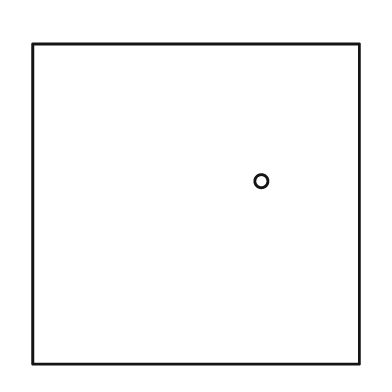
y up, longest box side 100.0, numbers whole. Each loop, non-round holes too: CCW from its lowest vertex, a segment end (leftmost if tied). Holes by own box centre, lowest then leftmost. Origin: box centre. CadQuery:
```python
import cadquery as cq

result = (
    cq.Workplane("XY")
    .moveTo(-50.0, -49.0)
    .lineTo(50.0, -49.0)
    .lineTo(50.0, 49.0)
    .lineTo(-50.0, 49.0)
    .close()
    .moveTo(20.0, 7.0)
    .circle(2.0)
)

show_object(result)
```